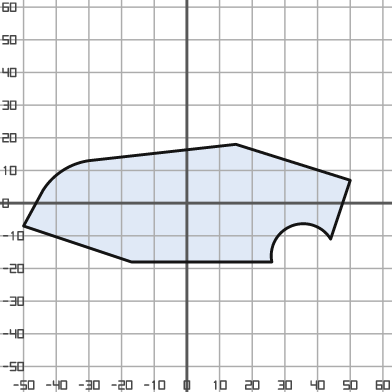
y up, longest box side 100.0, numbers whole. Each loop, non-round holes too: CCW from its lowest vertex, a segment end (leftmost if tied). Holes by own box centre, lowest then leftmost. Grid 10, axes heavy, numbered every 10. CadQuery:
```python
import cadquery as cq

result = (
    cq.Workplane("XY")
    .moveTo(-17.0, -18.0)
    .lineTo(26.0, -18.0)
    .threePointArc((32.0, -7.0), (44.0, -11.0))
    .lineTo(50.0, 7.0)
    .lineTo(15.0, 18.0)
    .lineTo(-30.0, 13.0)
    .threePointArc((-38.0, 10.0), (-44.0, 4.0))
    .lineTo(-50.0, -7.0)
    .close()
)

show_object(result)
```